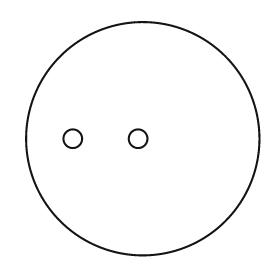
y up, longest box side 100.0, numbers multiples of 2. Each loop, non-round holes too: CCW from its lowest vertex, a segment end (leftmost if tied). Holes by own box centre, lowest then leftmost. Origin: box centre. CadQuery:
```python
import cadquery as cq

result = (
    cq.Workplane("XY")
    .moveTo(0.0, 0.0)
    .circle(50.0)
    .moveTo(-30.0, 0.0)
    .circle(4.0)
    .moveTo(-2.0, 0.0)
    .circle(4.0)
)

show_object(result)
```